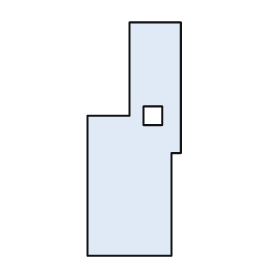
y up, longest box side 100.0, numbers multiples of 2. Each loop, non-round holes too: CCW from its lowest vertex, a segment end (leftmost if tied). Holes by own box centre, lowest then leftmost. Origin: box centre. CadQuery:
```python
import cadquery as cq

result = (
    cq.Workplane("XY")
    .moveTo(-20.0, -50.0)
    .lineTo(16.0, -50.0)
    .lineTo(16.0, -6.0)
    .lineTo(20.0, -6.0)
    .lineTo(20.0, 50.0)
    .lineTo(-2.0, 50.0)
    .lineTo(-2.0, 10.0)
    .lineTo(-20.0, 10.0)
    .close()
    .moveTo(4.0, 6.0)
    .lineTo(12.0, 6.0)
    .lineTo(12.0, 14.0)
    .lineTo(4.0, 14.0)
    .close()
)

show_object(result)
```